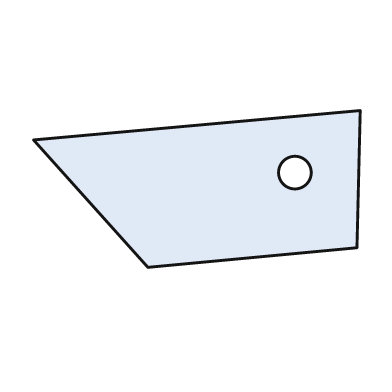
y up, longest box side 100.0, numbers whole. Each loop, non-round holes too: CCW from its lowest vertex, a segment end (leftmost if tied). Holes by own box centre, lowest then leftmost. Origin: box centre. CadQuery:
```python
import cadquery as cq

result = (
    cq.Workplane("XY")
    .moveTo(-15.0, -24.0)
    .lineTo(49.0, -18.0)
    .lineTo(50.0, 24.0)
    .lineTo(-50.0, 15.0)
    .close()
    .moveTo(30.0, 5.0)
    .circle(5.0)
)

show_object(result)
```